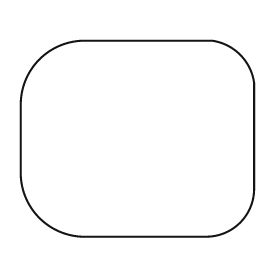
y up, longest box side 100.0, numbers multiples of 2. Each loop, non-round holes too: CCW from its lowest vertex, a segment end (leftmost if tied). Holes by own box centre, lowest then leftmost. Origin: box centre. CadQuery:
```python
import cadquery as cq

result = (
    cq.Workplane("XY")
    .moveTo(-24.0, -42.0)
    .lineTo(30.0, -42.0)
    .threePointArc((44.0, -36.0), (50.0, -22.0))
    .lineTo(50.0, 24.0)
    .threePointArc((44.0, 36.0), (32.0, 42.0))
    .lineTo(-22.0, 42.0)
    .threePointArc((-42.0, 34.0), (-50.0, 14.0))
    .lineTo(-50.0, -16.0)
    .threePointArc((-42.0, -34.0), (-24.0, -42.0))
    .close()
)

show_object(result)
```